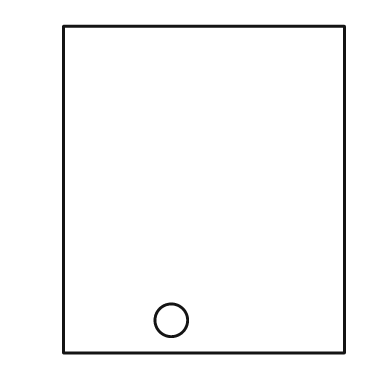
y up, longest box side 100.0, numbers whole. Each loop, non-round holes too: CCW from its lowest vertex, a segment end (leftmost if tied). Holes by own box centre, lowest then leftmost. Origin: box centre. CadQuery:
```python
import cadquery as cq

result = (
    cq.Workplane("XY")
    .moveTo(-43.0, -50.0)
    .lineTo(43.0, -50.0)
    .lineTo(43.0, 50.0)
    .lineTo(-43.0, 50.0)
    .close()
    .moveTo(-10.0, -40.0)
    .circle(5.0)
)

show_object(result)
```